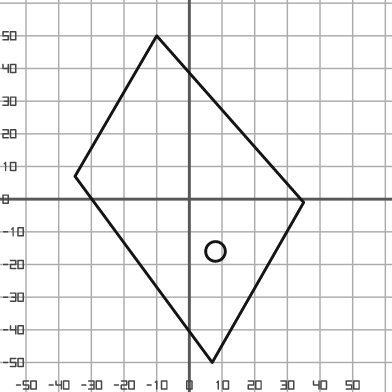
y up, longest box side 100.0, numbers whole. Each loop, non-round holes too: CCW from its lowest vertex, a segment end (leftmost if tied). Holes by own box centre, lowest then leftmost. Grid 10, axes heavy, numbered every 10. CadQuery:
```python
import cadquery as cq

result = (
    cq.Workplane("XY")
    .moveTo(7.0, -50.0)
    .lineTo(35.0, -1.0)
    .lineTo(-10.0, 50.0)
    .lineTo(-35.0, 7.0)
    .close()
    .moveTo(8.0, -16.0)
    .circle(3.0)
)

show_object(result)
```